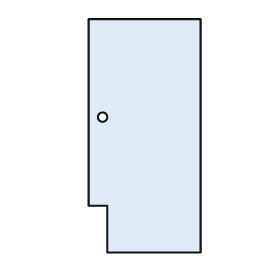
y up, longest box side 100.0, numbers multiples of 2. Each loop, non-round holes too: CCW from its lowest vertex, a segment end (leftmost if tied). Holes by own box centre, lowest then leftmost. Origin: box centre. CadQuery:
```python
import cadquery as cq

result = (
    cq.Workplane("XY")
    .moveTo(-16.0, -50.0)
    .lineTo(24.0, -50.0)
    .lineTo(24.0, 50.0)
    .lineTo(-24.0, 50.0)
    .lineTo(-24.0, -30.0)
    .lineTo(-16.0, -30.0)
    .close()
    .moveTo(-18.0, 8.0)
    .circle(2.0)
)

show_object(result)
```